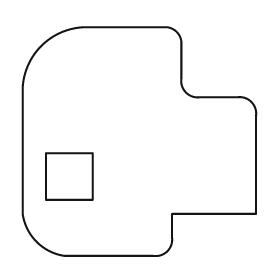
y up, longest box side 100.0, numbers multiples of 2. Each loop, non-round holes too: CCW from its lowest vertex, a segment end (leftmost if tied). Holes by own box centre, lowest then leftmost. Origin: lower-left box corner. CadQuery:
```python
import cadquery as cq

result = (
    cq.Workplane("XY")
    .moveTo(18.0, 0.0)
    .lineTo(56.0, 0.0)
    .threePointArc((62.0, 2.0), (64.0, 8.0))
    .lineTo(64.0, 18.0)
    .lineTo(100.0, 18.0)
    .lineTo(100.0, 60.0)
    .threePointArc((98.0, 66.0), (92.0, 68.0))
    .lineTo(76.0, 68.0)
    .threePointArc((70.0, 70.0), (68.0, 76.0))
    .lineTo(68.0, 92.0)
    .threePointArc((66.0, 96.0), (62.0, 98.0))
    .lineTo(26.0, 98.0)
    .threePointArc((8.0, 90.0), (0.0, 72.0))
    .lineTo(0.0, 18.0)
    .threePointArc((6.0, 6.0), (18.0, 0.0))
    .close()
    .moveTo(10.0, 24.0)
    .lineTo(30.0, 24.0)
    .lineTo(30.0, 44.0)
    .lineTo(10.0, 44.0)
    .close()
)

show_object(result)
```